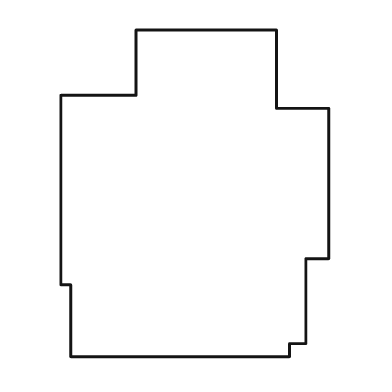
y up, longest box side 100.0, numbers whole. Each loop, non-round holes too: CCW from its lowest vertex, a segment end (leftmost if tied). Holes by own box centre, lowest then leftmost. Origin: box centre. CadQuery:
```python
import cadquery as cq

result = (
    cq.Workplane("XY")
    .moveTo(-38.0, -50.0)
    .lineTo(29.0, -50.0)
    .lineTo(29.0, -46.0)
    .lineTo(34.0, -46.0)
    .lineTo(34.0, -20.0)
    .lineTo(41.0, -20.0)
    .lineTo(41.0, 26.0)
    .lineTo(25.0, 26.0)
    .lineTo(25.0, 50.0)
    .lineTo(-18.0, 50.0)
    .lineTo(-18.0, 30.0)
    .lineTo(-41.0, 30.0)
    .lineTo(-41.0, -28.0)
    .lineTo(-38.0, -28.0)
    .close()
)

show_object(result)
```